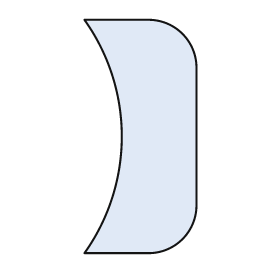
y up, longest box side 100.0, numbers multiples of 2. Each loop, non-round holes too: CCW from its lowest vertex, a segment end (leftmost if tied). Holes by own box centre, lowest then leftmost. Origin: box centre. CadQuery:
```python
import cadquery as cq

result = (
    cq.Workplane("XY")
    .moveTo(-24.0, -50.0)
    .lineTo(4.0, -50.0)
    .threePointArc((18.0, -44.0), (24.0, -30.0))
    .lineTo(24.0, 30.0)
    .threePointArc((18.0, 44.0), (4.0, 50.0))
    .lineTo(-24.0, 50.0)
    .threePointArc((-8.0, 0.0), (-24.0, -50.0))
    .close()
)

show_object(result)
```